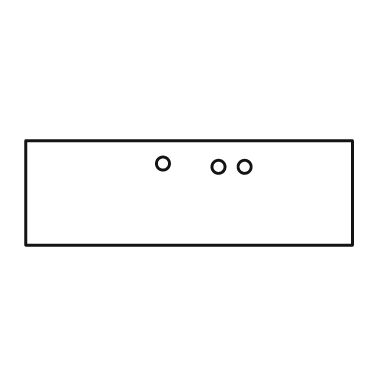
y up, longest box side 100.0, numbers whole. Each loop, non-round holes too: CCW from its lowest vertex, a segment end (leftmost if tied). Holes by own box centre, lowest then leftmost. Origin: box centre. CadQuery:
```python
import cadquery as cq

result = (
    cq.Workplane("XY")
    .moveTo(-50.0, -16.0)
    .lineTo(50.0, -16.0)
    .lineTo(50.0, 16.0)
    .lineTo(-50.0, 16.0)
    .close()
    .moveTo(9.0, 8.0)
    .circle(2.0)
    .moveTo(17.0, 8.0)
    .circle(2.0)
    .moveTo(-8.0, 9.0)
    .circle(2.0)
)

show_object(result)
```